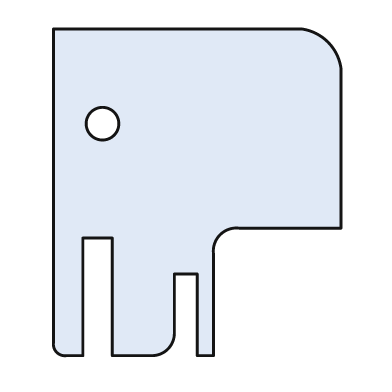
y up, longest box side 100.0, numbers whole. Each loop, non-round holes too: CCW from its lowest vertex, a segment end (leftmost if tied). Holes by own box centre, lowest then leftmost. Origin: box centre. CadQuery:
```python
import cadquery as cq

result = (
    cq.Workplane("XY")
    .moveTo(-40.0, -50.0)
    .lineTo(-35.0, -50.0)
    .lineTo(-35.0, -14.0)
    .lineTo(-26.0, -14.0)
    .lineTo(-26.0, -50.0)
    .lineTo(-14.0, -50.0)
    .threePointArc((-9.0, -48.0), (-7.0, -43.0))
    .lineTo(-7.0, -25.0)
    .lineTo(0.0, -25.0)
    .lineTo(0.0, -50.0)
    .lineTo(5.0, -50.0)
    .lineTo(5.0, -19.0)
    .threePointArc((7.0, -13.0), (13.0, -11.0))
    .lineTo(44.0, -11.0)
    .lineTo(44.0, 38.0)
    .threePointArc((40.0, 46.0), (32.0, 50.0))
    .lineTo(-44.0, 50.0)
    .lineTo(-44.0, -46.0)
    .threePointArc((-43.0, -49.0), (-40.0, -50.0))
    .close()
    .moveTo(-29.0, 21.0)
    .circle(5.0)
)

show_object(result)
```